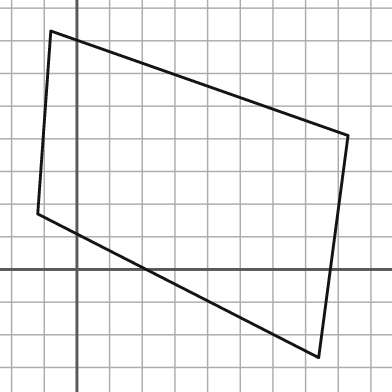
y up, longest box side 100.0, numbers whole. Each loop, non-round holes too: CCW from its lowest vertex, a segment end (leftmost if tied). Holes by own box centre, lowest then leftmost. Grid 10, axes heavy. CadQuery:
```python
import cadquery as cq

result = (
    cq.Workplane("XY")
    .moveTo(74.0, -27.0)
    .lineTo(83.0, 41.0)
    .lineTo(-8.0, 73.0)
    .lineTo(-12.0, 17.0)
    .close()
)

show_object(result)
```